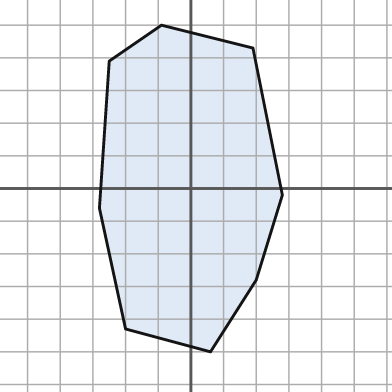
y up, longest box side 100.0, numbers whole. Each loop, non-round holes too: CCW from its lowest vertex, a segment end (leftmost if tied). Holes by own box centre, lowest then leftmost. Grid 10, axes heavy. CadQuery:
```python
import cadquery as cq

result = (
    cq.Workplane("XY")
    .moveTo(6.0, -50.0)
    .lineTo(20.0, -28.0)
    .lineTo(28.0, -2.0)
    .lineTo(19.0, 43.0)
    .lineTo(-9.0, 50.0)
    .lineTo(-25.0, 39.0)
    .lineTo(-28.0, -6.0)
    .lineTo(-20.0, -43.0)
    .close()
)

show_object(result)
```